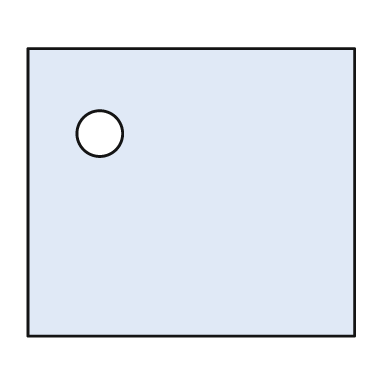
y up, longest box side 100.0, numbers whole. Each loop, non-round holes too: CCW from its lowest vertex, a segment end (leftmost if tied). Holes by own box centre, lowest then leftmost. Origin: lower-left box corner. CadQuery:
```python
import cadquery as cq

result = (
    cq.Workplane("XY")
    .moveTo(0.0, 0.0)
    .lineTo(100.0, 0.0)
    .lineTo(100.0, 88.0)
    .lineTo(0.0, 88.0)
    .close()
    .moveTo(22.0, 62.0)
    .circle(7.0)
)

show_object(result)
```